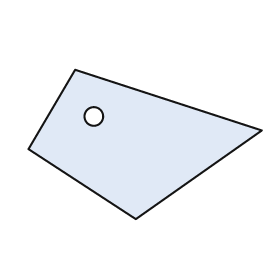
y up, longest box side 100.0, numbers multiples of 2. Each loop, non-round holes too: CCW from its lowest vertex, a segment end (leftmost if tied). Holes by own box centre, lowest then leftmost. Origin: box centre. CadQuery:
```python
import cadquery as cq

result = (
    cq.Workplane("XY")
    .moveTo(-4.0, -32.0)
    .lineTo(50.0, 6.0)
    .lineTo(-30.0, 32.0)
    .lineTo(-50.0, -2.0)
    .close()
    .moveTo(-22.0, 12.0)
    .circle(4.0)
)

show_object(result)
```